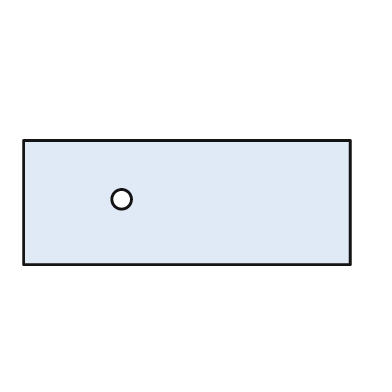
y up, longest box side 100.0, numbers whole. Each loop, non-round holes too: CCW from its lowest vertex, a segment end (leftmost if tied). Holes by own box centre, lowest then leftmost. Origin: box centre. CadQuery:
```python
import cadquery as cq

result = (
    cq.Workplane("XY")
    .moveTo(-50.0, -19.0)
    .lineTo(50.0, -19.0)
    .lineTo(50.0, 19.0)
    .lineTo(-50.0, 19.0)
    .close()
    .moveTo(-20.0, 1.0)
    .circle(3.0)
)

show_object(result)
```